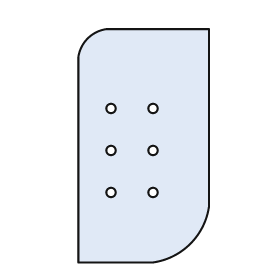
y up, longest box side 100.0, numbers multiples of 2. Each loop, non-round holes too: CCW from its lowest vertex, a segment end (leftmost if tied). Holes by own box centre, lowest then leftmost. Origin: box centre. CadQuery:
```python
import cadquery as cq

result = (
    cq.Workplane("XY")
    .moveTo(-28.0, -50.0)
    .lineTo(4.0, -50.0)
    .threePointArc((20.0, -42.0), (28.0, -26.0))
    .lineTo(28.0, 50.0)
    .lineTo(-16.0, 50.0)
    .threePointArc((-24.0, 46.0), (-28.0, 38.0))
    .close()
    .moveTo(-14.0, -20.0)
    .circle(2.0)
    .moveTo(4.0, -20.0)
    .circle(2.0)
    .moveTo(-14.0, -2.0)
    .circle(2.0)
    .moveTo(4.0, -2.0)
    .circle(2.0)
    .moveTo(-14.0, 16.0)
    .circle(2.0)
    .moveTo(4.0, 16.0)
    .circle(2.0)
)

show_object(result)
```